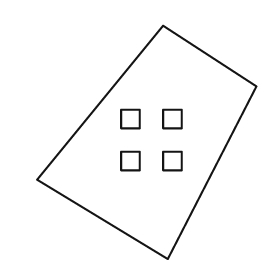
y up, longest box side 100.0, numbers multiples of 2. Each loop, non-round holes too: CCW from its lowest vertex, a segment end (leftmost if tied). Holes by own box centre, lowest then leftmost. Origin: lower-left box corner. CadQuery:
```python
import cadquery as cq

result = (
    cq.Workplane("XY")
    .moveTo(56.0, 0.0)
    .lineTo(94.0, 74.0)
    .lineTo(54.0, 100.0)
    .lineTo(0.0, 34.0)
    .close()
    .moveTo(36.0, 38.0)
    .lineTo(44.0, 38.0)
    .lineTo(44.0, 46.0)
    .lineTo(36.0, 46.0)
    .close()
    .moveTo(54.0, 38.0)
    .lineTo(62.0, 38.0)
    .lineTo(62.0, 46.0)
    .lineTo(54.0, 46.0)
    .close()
    .moveTo(36.0, 56.0)
    .lineTo(44.0, 56.0)
    .lineTo(44.0, 64.0)
    .lineTo(36.0, 64.0)
    .close()
    .moveTo(54.0, 56.0)
    .lineTo(62.0, 56.0)
    .lineTo(62.0, 64.0)
    .lineTo(54.0, 64.0)
    .close()
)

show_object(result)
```